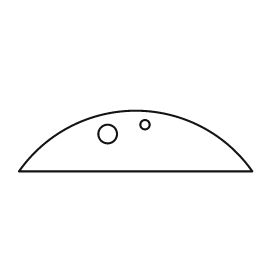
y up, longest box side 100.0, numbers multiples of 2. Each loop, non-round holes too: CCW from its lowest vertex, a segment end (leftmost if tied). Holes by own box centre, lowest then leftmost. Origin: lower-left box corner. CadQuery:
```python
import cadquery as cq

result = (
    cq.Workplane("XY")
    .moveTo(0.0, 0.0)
    .lineTo(100.0, 0.0)
    .threePointArc((50.0, 26.0), (0.0, 0.0))
    .close()
    .moveTo(38.0, 16.0)
    .circle(4.0)
    .moveTo(54.0, 20.0)
    .circle(2.0)
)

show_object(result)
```